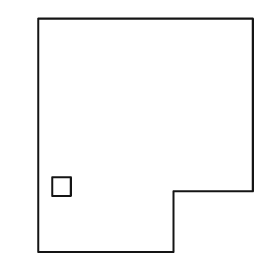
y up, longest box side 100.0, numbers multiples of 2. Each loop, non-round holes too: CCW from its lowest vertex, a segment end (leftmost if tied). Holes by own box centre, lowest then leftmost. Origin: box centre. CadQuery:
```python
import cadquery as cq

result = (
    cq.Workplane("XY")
    .moveTo(-46.0, -50.0)
    .lineTo(12.0, -50.0)
    .lineTo(12.0, -24.0)
    .lineTo(46.0, -24.0)
    .lineTo(46.0, 50.0)
    .lineTo(-46.0, 50.0)
    .close()
    .moveTo(-40.0, -26.0)
    .lineTo(-32.0, -26.0)
    .lineTo(-32.0, -18.0)
    .lineTo(-40.0, -18.0)
    .close()
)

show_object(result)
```